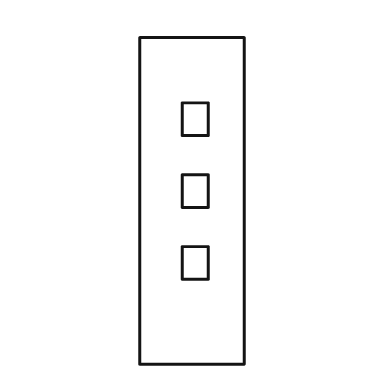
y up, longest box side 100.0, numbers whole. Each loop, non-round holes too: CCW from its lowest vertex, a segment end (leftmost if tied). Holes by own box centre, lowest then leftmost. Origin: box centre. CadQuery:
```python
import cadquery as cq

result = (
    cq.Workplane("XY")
    .moveTo(-16.0, -50.0)
    .lineTo(16.0, -50.0)
    .lineTo(16.0, 50.0)
    .lineTo(-16.0, 50.0)
    .close()
    .moveTo(-3.0, -24.0)
    .lineTo(5.0, -24.0)
    .lineTo(5.0, -14.0)
    .lineTo(-3.0, -14.0)
    .close()
    .moveTo(-3.0, -2.0)
    .lineTo(5.0, -2.0)
    .lineTo(5.0, 8.0)
    .lineTo(-3.0, 8.0)
    .close()
    .moveTo(-3.0, 20.0)
    .lineTo(5.0, 20.0)
    .lineTo(5.0, 30.0)
    .lineTo(-3.0, 30.0)
    .close()
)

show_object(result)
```